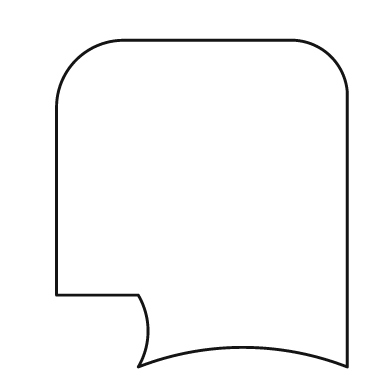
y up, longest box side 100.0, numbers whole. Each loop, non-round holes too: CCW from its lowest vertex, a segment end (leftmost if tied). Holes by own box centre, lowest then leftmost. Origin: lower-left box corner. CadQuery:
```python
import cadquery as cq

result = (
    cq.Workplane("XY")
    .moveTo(25.0, 0.0)
    .threePointArc((57.0, 6.0), (89.0, 0.0))
    .lineTo(89.0, 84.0)
    .threePointArc((84.0, 95.0), (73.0, 100.0))
    .lineTo(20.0, 100.0)
    .threePointArc((6.0, 94.0), (0.0, 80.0))
    .lineTo(0.0, 22.0)
    .lineTo(25.0, 22.0)
    .threePointArc((28.0, 11.0), (25.0, 0.0))
    .close()
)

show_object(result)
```